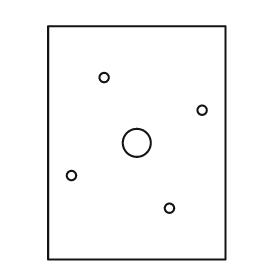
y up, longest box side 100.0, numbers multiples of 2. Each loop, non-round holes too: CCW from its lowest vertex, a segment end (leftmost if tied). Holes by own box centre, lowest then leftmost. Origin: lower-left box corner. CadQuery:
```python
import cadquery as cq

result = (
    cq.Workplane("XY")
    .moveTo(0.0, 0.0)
    .lineTo(76.0, 0.0)
    .lineTo(76.0, 100.0)
    .lineTo(0.0, 100.0)
    .close()
    .moveTo(52.0, 22.0)
    .circle(2.0)
    .moveTo(10.0, 36.0)
    .circle(2.0)
    .moveTo(38.0, 50.0)
    .circle(6.0)
    .moveTo(66.0, 64.0)
    .circle(2.0)
    .moveTo(24.0, 78.0)
    .circle(2.0)
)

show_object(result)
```